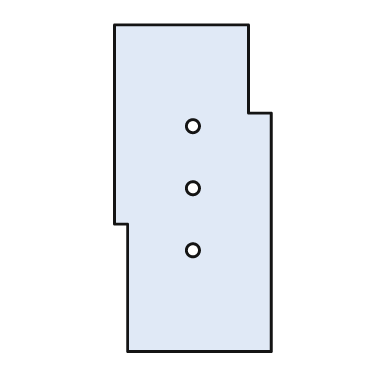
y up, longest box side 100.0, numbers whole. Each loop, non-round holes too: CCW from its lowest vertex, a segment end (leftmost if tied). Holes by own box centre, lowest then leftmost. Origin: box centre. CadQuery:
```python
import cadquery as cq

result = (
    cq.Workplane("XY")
    .moveTo(-20.0, -50.0)
    .lineTo(24.0, -50.0)
    .lineTo(24.0, 23.0)
    .lineTo(17.0, 23.0)
    .lineTo(17.0, 50.0)
    .lineTo(-24.0, 50.0)
    .lineTo(-24.0, -11.0)
    .lineTo(-20.0, -11.0)
    .close()
    .moveTo(0.0, -19.0)
    .circle(2.0)
    .moveTo(0.0, 0.0)
    .circle(2.0)
    .moveTo(0.0, 19.0)
    .circle(2.0)
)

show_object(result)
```